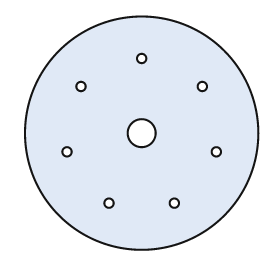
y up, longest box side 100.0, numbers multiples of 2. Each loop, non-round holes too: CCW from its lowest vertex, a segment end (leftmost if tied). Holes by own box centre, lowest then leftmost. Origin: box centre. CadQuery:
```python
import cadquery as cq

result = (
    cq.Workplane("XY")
    .moveTo(0.0, 0.0)
    .circle(50.0)
    .moveTo(-14.0, -30.0)
    .circle(2.0)
    .moveTo(14.0, -30.0)
    .circle(2.0)
    .moveTo(-32.0, -8.0)
    .circle(2.0)
    .moveTo(32.0, -8.0)
    .circle(2.0)
    .moveTo(0.0, 0.0)
    .circle(6.0)
    .moveTo(-26.0, 20.0)
    .circle(2.0)
    .moveTo(26.0, 20.0)
    .circle(2.0)
    .moveTo(0.0, 32.0)
    .circle(2.0)
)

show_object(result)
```